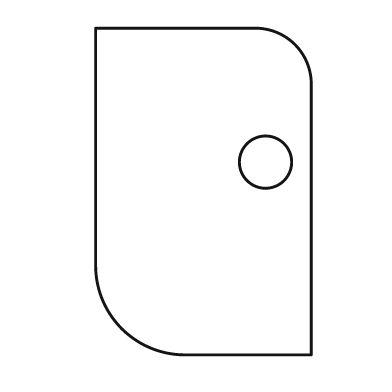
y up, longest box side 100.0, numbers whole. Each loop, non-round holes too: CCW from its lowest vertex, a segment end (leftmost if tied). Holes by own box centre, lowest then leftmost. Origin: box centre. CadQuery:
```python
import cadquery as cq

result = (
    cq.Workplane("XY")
    .moveTo(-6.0, -50.0)
    .lineTo(33.0, -50.0)
    .lineTo(33.0, 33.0)
    .threePointArc((28.0, 45.0), (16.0, 50.0))
    .lineTo(-33.0, 50.0)
    .lineTo(-33.0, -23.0)
    .threePointArc((-25.0, -42.0), (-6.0, -50.0))
    .close()
    .moveTo(19.0, 9.0)
    .circle(8.0)
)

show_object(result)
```